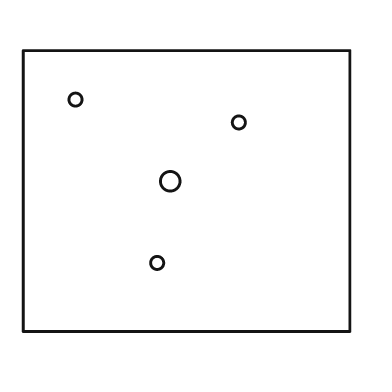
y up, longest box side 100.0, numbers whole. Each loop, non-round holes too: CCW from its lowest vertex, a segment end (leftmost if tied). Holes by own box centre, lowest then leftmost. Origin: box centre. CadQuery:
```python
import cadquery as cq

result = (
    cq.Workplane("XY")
    .moveTo(-50.0, -43.0)
    .lineTo(50.0, -43.0)
    .lineTo(50.0, 43.0)
    .lineTo(-50.0, 43.0)
    .close()
    .moveTo(-9.0, -22.0)
    .circle(2.0)
    .moveTo(-5.0, 3.0)
    .circle(3.0)
    .moveTo(16.0, 21.0)
    .circle(2.0)
    .moveTo(-34.0, 28.0)
    .circle(2.0)
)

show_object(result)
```